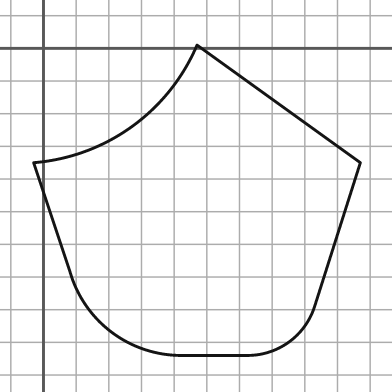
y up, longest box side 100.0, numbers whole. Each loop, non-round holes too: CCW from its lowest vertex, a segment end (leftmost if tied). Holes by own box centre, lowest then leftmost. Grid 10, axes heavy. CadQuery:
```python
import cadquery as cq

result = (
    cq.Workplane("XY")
    .moveTo(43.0, -94.0)
    .lineTo(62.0, -94.0)
    .threePointArc((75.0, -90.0), (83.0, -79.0))
    .lineTo(97.0, -35.0)
    .lineTo(47.0, 1.0)
    .threePointArc((27.0, -24.0), (-3.0, -35.0))
    .lineTo(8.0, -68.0)
    .threePointArc((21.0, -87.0), (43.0, -94.0))
    .close()
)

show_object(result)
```